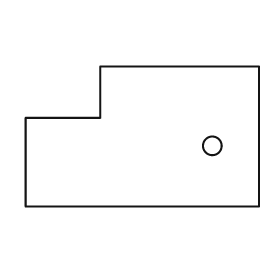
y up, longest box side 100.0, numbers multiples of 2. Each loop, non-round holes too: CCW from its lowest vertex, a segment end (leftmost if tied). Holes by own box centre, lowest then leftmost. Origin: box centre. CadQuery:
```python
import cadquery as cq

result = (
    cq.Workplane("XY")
    .moveTo(-50.0, -30.0)
    .lineTo(50.0, -30.0)
    .lineTo(50.0, 30.0)
    .lineTo(-18.0, 30.0)
    .lineTo(-18.0, 8.0)
    .lineTo(-50.0, 8.0)
    .close()
    .moveTo(30.0, -4.0)
    .circle(4.0)
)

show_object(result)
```